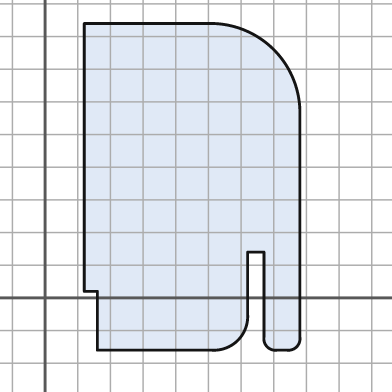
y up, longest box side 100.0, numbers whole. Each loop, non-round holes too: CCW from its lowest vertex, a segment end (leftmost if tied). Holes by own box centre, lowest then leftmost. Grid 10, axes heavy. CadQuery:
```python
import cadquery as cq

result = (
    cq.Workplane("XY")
    .moveTo(16.0, -16.0)
    .lineTo(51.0, -16.0)
    .threePointArc((59.0, -13.0), (62.0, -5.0))
    .lineTo(62.0, 14.0)
    .lineTo(67.0, 14.0)
    .lineTo(67.0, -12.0)
    .threePointArc((68.0, -15.0), (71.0, -16.0))
    .lineTo(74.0, -16.0)
    .threePointArc((77.0, -15.0), (78.0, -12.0))
    .lineTo(78.0, 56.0)
    .threePointArc((70.0, 76.0), (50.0, 84.0))
    .lineTo(12.0, 84.0)
    .lineTo(12.0, 2.0)
    .lineTo(16.0, 2.0)
    .close()
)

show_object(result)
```